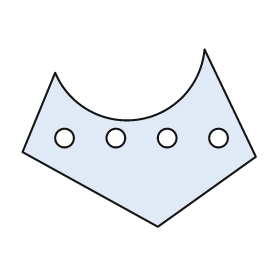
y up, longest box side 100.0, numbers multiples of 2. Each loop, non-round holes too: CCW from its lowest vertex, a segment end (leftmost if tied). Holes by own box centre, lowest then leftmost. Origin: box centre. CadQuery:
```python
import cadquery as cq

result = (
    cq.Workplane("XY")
    .moveTo(8.0, -38.0)
    .lineTo(50.0, -8.0)
    .lineTo(28.0, 38.0)
    .threePointArc((0.0, 8.0), (-36.0, 28.0))
    .lineTo(-50.0, -6.0)
    .close()
    .moveTo(-32.0, 0.0)
    .circle(4.0)
    .moveTo(-10.0, 0.0)
    .circle(4.0)
    .moveTo(12.0, 0.0)
    .circle(4.0)
    .moveTo(34.0, 0.0)
    .circle(4.0)
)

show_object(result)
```